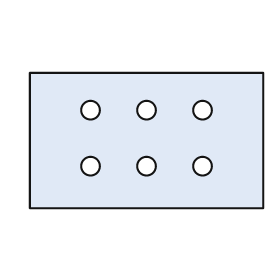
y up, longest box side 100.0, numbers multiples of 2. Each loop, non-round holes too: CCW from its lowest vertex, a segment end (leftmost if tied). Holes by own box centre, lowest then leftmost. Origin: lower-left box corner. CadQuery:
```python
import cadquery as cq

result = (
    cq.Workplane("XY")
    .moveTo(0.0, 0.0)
    .lineTo(100.0, 0.0)
    .lineTo(100.0, 58.0)
    .lineTo(0.0, 58.0)
    .close()
    .moveTo(26.0, 18.0)
    .circle(4.0)
    .moveTo(50.0, 18.0)
    .circle(4.0)
    .moveTo(74.0, 18.0)
    .circle(4.0)
    .moveTo(26.0, 42.0)
    .circle(4.0)
    .moveTo(50.0, 42.0)
    .circle(4.0)
    .moveTo(74.0, 42.0)
    .circle(4.0)
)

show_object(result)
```